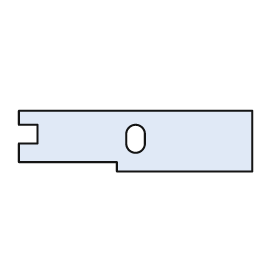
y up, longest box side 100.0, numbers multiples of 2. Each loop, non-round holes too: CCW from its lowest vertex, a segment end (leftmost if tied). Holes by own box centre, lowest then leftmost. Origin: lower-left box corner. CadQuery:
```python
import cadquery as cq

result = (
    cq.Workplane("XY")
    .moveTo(42.0, 0.0)
    .lineTo(100.0, 0.0)
    .lineTo(100.0, 26.0)
    .lineTo(0.0, 26.0)
    .lineTo(0.0, 20.0)
    .lineTo(8.0, 20.0)
    .lineTo(8.0, 12.0)
    .lineTo(0.0, 12.0)
    .lineTo(0.0, 4.0)
    .lineTo(42.0, 4.0)
    .close()
    .moveTo(46.0, 12.0)
    .threePointArc((50.0, 8.0), (54.0, 12.0))
    .lineTo(54.0, 16.0)
    .threePointArc((50.0, 20.0), (46.0, 16.0))
    .close()
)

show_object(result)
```